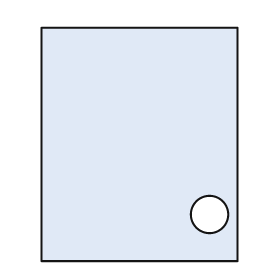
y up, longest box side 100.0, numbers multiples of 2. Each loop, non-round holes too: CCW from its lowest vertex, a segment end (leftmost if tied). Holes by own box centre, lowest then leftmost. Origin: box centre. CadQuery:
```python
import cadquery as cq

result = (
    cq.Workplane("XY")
    .moveTo(-42.0, -50.0)
    .lineTo(42.0, -50.0)
    .lineTo(42.0, 50.0)
    .lineTo(-42.0, 50.0)
    .close()
    .moveTo(30.0, -30.0)
    .circle(8.0)
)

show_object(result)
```